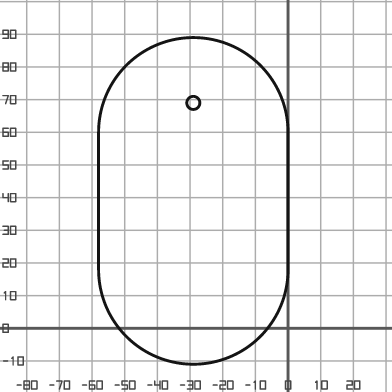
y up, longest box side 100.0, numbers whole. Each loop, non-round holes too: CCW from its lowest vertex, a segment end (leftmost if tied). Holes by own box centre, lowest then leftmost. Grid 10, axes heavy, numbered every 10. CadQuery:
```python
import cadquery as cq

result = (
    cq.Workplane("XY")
    .moveTo(-58.0, 18.0)
    .threePointArc((-29.0, -11.0), (0.0, 18.0))
    .lineTo(0.0, 60.0)
    .threePointArc((-29.0, 89.0), (-58.0, 60.0))
    .close()
    .moveTo(-29.0, 69.0)
    .circle(2.0)
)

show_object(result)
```